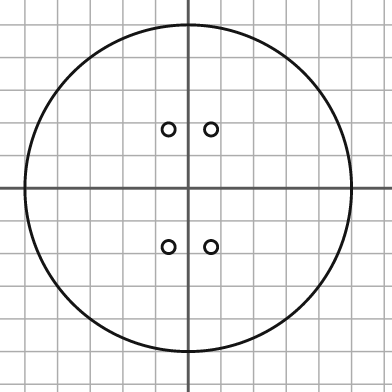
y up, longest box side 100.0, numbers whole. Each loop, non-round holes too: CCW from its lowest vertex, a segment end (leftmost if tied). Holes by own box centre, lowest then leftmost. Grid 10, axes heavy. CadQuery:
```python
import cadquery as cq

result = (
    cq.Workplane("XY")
    .moveTo(0.0, 0.0)
    .circle(50.0)
    .moveTo(-6.0, -18.0)
    .circle(2.0)
    .moveTo(7.0, -18.0)
    .circle(2.0)
    .moveTo(-6.0, 18.0)
    .circle(2.0)
    .moveTo(7.0, 18.0)
    .circle(2.0)
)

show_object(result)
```